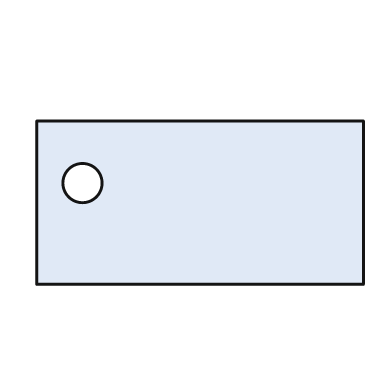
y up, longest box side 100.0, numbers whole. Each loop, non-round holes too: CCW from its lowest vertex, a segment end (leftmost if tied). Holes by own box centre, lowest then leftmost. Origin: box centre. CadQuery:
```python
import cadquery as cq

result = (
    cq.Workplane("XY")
    .moveTo(-50.0, -25.0)
    .lineTo(50.0, -25.0)
    .lineTo(50.0, 25.0)
    .lineTo(-50.0, 25.0)
    .close()
    .moveTo(-36.0, 6.0)
    .circle(6.0)
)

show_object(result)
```